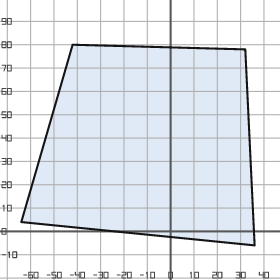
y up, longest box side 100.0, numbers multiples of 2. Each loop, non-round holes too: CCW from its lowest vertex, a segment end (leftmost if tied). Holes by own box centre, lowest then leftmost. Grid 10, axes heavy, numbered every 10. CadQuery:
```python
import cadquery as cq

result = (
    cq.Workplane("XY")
    .moveTo(36.0, -6.0)
    .lineTo(32.0, 78.0)
    .lineTo(-42.0, 80.0)
    .lineTo(-64.0, 4.0)
    .close()
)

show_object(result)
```